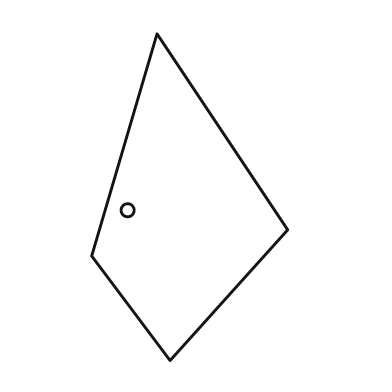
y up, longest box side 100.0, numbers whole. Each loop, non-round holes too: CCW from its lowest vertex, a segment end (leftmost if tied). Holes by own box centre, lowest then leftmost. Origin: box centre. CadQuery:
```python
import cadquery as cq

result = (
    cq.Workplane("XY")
    .moveTo(-6.0, -50.0)
    .lineTo(30.0, -10.0)
    .lineTo(-10.0, 50.0)
    .lineTo(-30.0, -18.0)
    .close()
    .moveTo(-19.0, -4.0)
    .circle(2.0)
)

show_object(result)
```